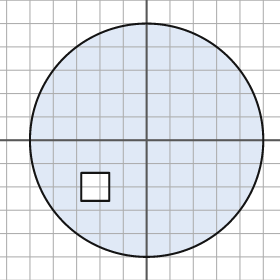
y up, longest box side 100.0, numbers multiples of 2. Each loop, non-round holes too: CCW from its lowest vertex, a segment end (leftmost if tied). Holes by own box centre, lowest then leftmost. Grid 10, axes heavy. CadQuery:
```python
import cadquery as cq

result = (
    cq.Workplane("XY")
    .moveTo(0.0, 0.0)
    .circle(50.0)
    .moveTo(-28.0, -26.0)
    .lineTo(-16.0, -26.0)
    .lineTo(-16.0, -14.0)
    .lineTo(-28.0, -14.0)
    .close()
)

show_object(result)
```